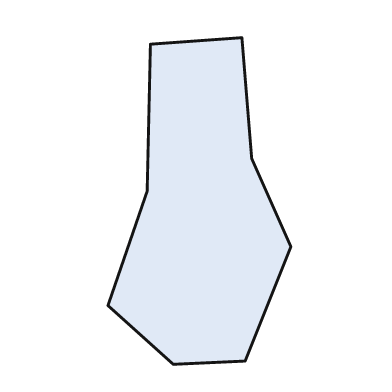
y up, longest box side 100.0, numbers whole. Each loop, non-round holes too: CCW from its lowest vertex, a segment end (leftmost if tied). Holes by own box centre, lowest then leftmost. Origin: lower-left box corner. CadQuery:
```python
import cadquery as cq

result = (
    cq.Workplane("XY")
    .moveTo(20.0, 0.0)
    .lineTo(42.0, 1.0)
    .lineTo(56.0, 36.0)
    .lineTo(44.0, 63.0)
    .lineTo(41.0, 100.0)
    .lineTo(13.0, 98.0)
    .lineTo(12.0, 53.0)
    .lineTo(0.0, 18.0)
    .close()
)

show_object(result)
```